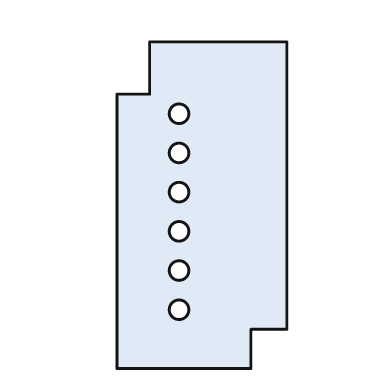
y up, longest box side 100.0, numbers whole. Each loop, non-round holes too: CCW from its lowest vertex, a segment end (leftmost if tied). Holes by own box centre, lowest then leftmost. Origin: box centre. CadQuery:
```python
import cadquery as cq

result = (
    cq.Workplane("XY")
    .moveTo(-26.0, -50.0)
    .lineTo(15.0, -50.0)
    .lineTo(15.0, -38.0)
    .lineTo(26.0, -38.0)
    .lineTo(26.0, 50.0)
    .lineTo(-16.0, 50.0)
    .lineTo(-16.0, 34.0)
    .lineTo(-26.0, 34.0)
    .close()
    .moveTo(-7.0, -32.0)
    .circle(3.0)
    .moveTo(-7.0, -20.0)
    .circle(3.0)
    .moveTo(-7.0, -8.0)
    .circle(3.0)
    .moveTo(-7.0, 4.0)
    .circle(3.0)
    .moveTo(-7.0, 16.0)
    .circle(3.0)
    .moveTo(-7.0, 28.0)
    .circle(3.0)
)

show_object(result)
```